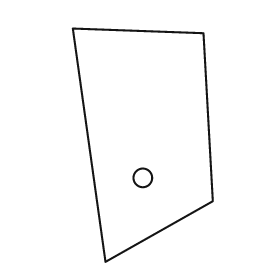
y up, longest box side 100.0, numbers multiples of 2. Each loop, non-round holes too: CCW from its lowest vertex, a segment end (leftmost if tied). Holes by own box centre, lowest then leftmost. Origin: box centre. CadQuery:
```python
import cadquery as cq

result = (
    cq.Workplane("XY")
    .moveTo(-16.0, -50.0)
    .lineTo(30.0, -24.0)
    .lineTo(26.0, 48.0)
    .lineTo(-30.0, 50.0)
    .close()
    .moveTo(0.0, -14.0)
    .circle(4.0)
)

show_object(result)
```